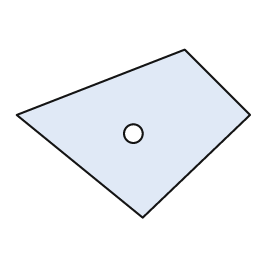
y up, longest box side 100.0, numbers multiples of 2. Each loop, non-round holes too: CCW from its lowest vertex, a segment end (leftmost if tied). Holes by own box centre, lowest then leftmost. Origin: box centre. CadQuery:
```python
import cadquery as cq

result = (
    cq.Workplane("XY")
    .moveTo(4.0, -36.0)
    .lineTo(50.0, 8.0)
    .lineTo(22.0, 36.0)
    .lineTo(-50.0, 8.0)
    .close()
    .moveTo(0.0, 0.0)
    .circle(4.0)
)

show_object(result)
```